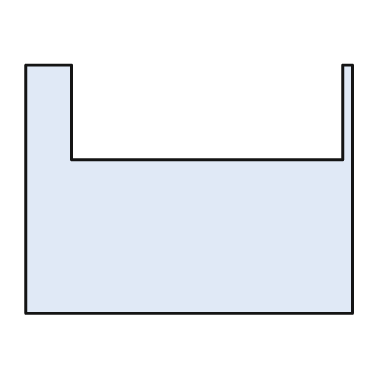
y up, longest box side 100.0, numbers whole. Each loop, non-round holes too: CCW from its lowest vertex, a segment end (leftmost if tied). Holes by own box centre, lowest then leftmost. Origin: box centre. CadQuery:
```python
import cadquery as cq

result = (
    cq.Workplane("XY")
    .moveTo(-50.0, -38.0)
    .lineTo(50.0, -38.0)
    .lineTo(50.0, 38.0)
    .lineTo(47.0, 38.0)
    .lineTo(47.0, 9.0)
    .lineTo(-36.0, 9.0)
    .lineTo(-36.0, 38.0)
    .lineTo(-50.0, 38.0)
    .close()
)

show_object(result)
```